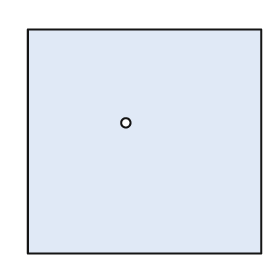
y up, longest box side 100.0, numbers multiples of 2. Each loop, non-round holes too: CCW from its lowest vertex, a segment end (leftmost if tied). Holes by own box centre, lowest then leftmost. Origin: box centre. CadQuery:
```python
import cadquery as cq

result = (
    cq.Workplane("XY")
    .moveTo(-50.0, -48.0)
    .lineTo(50.0, -48.0)
    .lineTo(50.0, 48.0)
    .lineTo(-50.0, 48.0)
    .close()
    .moveTo(-8.0, 8.0)
    .circle(2.0)
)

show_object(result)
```